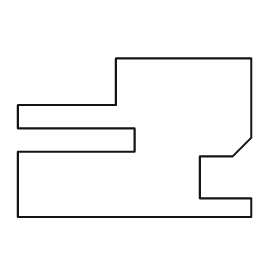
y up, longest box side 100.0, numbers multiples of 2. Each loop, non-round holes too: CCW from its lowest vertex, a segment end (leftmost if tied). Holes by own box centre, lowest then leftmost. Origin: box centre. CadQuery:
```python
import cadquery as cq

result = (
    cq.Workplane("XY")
    .moveTo(-50.0, -34.0)
    .lineTo(50.0, -34.0)
    .lineTo(50.0, -26.0)
    .lineTo(28.0, -26.0)
    .lineTo(28.0, -8.0)
    .lineTo(42.0, -8.0)
    .lineTo(50.0, 0.0)
    .lineTo(50.0, 34.0)
    .lineTo(-8.0, 34.0)
    .lineTo(-8.0, 14.0)
    .lineTo(-50.0, 14.0)
    .lineTo(-50.0, 4.0)
    .lineTo(0.0, 4.0)
    .lineTo(0.0, -6.0)
    .lineTo(-50.0, -6.0)
    .close()
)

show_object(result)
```